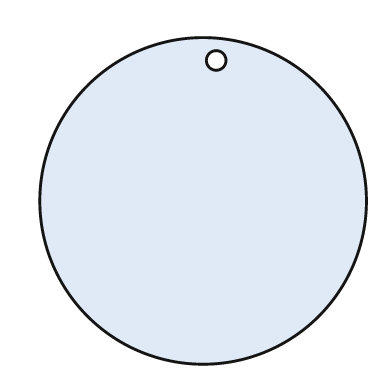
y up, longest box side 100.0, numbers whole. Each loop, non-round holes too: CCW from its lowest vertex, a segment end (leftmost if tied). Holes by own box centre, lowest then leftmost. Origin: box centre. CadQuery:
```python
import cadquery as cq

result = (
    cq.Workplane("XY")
    .moveTo(0.0, 0.0)
    .circle(50.0)
    .moveTo(4.0, 43.0)
    .circle(3.0)
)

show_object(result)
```